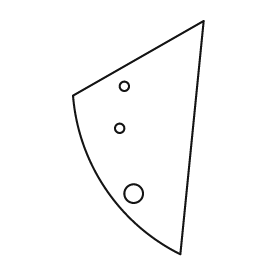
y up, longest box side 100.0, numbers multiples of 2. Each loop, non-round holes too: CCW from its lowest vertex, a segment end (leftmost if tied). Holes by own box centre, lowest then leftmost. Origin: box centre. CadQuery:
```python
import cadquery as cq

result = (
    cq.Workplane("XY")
    .moveTo(18.0, -50.0)
    .lineTo(28.0, 50.0)
    .lineTo(-28.0, 18.0)
    .threePointArc((-14.0, -22.0), (18.0, -50.0))
    .close()
    .moveTo(-2.0, -24.0)
    .circle(4.0)
    .moveTo(-8.0, 4.0)
    .circle(2.0)
    .moveTo(-6.0, 22.0)
    .circle(2.0)
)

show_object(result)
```